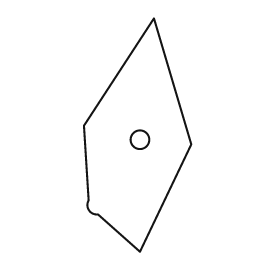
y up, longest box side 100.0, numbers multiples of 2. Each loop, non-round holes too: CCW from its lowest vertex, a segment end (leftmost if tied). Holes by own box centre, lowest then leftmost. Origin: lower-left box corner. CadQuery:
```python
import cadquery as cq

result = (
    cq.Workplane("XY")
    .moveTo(24.0, 0.0)
    .lineTo(46.0, 46.0)
    .lineTo(30.0, 100.0)
    .lineTo(0.0, 54.0)
    .lineTo(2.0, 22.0)
    .threePointArc((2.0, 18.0), (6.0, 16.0))
    .close()
    .moveTo(24.0, 48.0)
    .circle(4.0)
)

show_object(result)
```